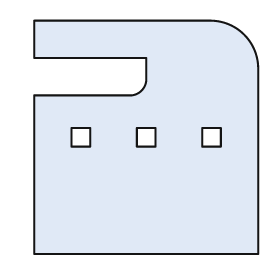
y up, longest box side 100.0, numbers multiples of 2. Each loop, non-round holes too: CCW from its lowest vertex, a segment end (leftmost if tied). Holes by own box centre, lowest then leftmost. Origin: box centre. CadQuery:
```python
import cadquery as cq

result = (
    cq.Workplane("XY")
    .moveTo(-48.0, -50.0)
    .lineTo(48.0, -50.0)
    .lineTo(48.0, 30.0)
    .threePointArc((42.0, 44.0), (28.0, 50.0))
    .lineTo(-48.0, 50.0)
    .lineTo(-48.0, 34.0)
    .lineTo(0.0, 34.0)
    .lineTo(0.0, 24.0)
    .threePointArc((-2.0, 20.0), (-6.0, 18.0))
    .lineTo(-48.0, 18.0)
    .close()
    .moveTo(-32.0, -4.0)
    .lineTo(-24.0, -4.0)
    .lineTo(-24.0, 4.0)
    .lineTo(-32.0, 4.0)
    .close()
    .moveTo(-4.0, -4.0)
    .lineTo(4.0, -4.0)
    .lineTo(4.0, 4.0)
    .lineTo(-4.0, 4.0)
    .close()
    .moveTo(24.0, -4.0)
    .lineTo(32.0, -4.0)
    .lineTo(32.0, 4.0)
    .lineTo(24.0, 4.0)
    .close()
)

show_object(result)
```